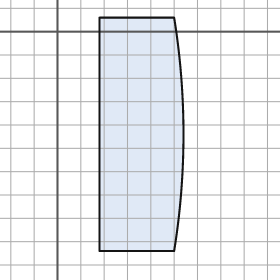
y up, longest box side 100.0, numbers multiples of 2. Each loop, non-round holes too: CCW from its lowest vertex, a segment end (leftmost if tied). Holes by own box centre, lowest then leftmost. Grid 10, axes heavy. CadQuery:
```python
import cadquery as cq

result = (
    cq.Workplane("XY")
    .moveTo(18.0, -94.0)
    .lineTo(50.0, -94.0)
    .threePointArc((54.0, -44.0), (50.0, 6.0))
    .lineTo(18.0, 6.0)
    .close()
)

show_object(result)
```